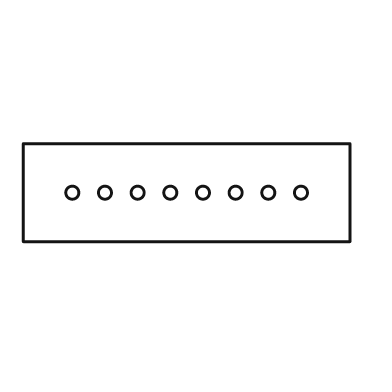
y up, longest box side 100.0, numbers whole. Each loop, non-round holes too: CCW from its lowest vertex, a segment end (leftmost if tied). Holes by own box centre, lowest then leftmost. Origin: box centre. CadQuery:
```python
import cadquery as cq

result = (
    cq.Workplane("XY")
    .moveTo(-50.0, -15.0)
    .lineTo(50.0, -15.0)
    .lineTo(50.0, 15.0)
    .lineTo(-50.0, 15.0)
    .close()
    .moveTo(-35.0, 0.0)
    .circle(2.0)
    .moveTo(-25.0, 0.0)
    .circle(2.0)
    .moveTo(-15.0, 0.0)
    .circle(2.0)
    .moveTo(-5.0, 0.0)
    .circle(2.0)
    .moveTo(5.0, 0.0)
    .circle(2.0)
    .moveTo(15.0, 0.0)
    .circle(2.0)
    .moveTo(25.0, 0.0)
    .circle(2.0)
    .moveTo(35.0, 0.0)
    .circle(2.0)
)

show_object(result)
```